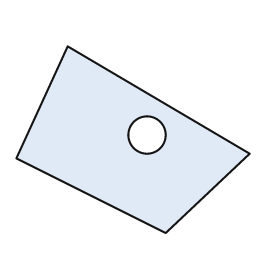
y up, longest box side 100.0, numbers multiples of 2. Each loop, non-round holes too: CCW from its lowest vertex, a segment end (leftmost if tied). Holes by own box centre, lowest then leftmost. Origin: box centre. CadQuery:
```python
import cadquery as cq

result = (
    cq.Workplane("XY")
    .moveTo(14.0, -40.0)
    .lineTo(50.0, -6.0)
    .lineTo(-28.0, 40.0)
    .lineTo(-50.0, -8.0)
    .close()
    .moveTo(6.0, 2.0)
    .circle(8.0)
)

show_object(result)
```